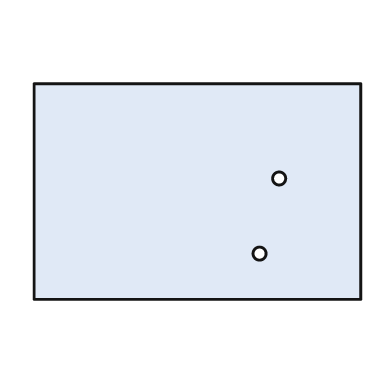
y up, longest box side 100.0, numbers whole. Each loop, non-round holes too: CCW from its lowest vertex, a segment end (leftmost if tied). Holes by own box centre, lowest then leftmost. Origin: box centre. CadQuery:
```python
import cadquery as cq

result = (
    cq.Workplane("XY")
    .moveTo(-50.0, -33.0)
    .lineTo(50.0, -33.0)
    .lineTo(50.0, 33.0)
    .lineTo(-50.0, 33.0)
    .close()
    .moveTo(19.0, -19.0)
    .circle(2.0)
    .moveTo(25.0, 4.0)
    .circle(2.0)
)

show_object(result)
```